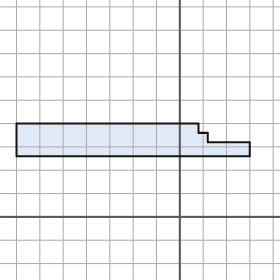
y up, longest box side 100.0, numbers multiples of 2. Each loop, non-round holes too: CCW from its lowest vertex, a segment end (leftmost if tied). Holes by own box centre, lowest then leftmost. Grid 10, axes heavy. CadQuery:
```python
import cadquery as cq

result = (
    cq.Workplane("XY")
    .moveTo(-70.0, 26.0)
    .lineTo(30.0, 26.0)
    .lineTo(30.0, 32.0)
    .lineTo(12.0, 32.0)
    .lineTo(12.0, 36.0)
    .lineTo(8.0, 36.0)
    .lineTo(8.0, 40.0)
    .lineTo(-70.0, 40.0)
    .close()
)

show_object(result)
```